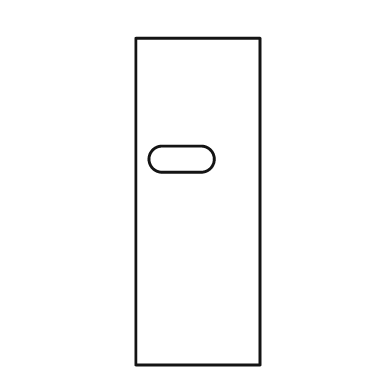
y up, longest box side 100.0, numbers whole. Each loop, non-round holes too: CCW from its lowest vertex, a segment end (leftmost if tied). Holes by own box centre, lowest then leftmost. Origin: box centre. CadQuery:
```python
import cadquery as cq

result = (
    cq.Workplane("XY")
    .moveTo(-19.0, -50.0)
    .lineTo(19.0, -50.0)
    .lineTo(19.0, 50.0)
    .lineTo(-19.0, 50.0)
    .close()
    .moveTo(-11.0, 9.0)
    .lineTo(1.0, 9.0)
    .threePointArc((5.0, 13.0), (1.0, 17.0))
    .lineTo(-11.0, 17.0)
    .threePointArc((-15.0, 13.0), (-11.0, 9.0))
    .close()
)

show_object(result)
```